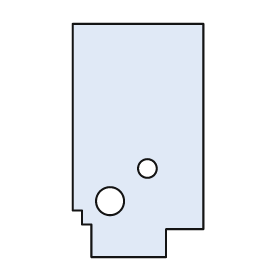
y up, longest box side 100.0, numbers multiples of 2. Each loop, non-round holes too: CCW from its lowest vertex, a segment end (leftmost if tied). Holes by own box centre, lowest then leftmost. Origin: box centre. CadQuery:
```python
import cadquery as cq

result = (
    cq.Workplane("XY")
    .moveTo(-20.0, -50.0)
    .lineTo(12.0, -50.0)
    .lineTo(12.0, -38.0)
    .lineTo(28.0, -38.0)
    .lineTo(28.0, 50.0)
    .lineTo(-28.0, 50.0)
    .lineTo(-28.0, -30.0)
    .lineTo(-24.0, -30.0)
    .lineTo(-24.0, -36.0)
    .lineTo(-20.0, -36.0)
    .close()
    .moveTo(-12.0, -26.0)
    .circle(6.0)
    .moveTo(4.0, -12.0)
    .circle(4.0)
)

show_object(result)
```